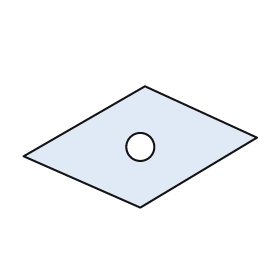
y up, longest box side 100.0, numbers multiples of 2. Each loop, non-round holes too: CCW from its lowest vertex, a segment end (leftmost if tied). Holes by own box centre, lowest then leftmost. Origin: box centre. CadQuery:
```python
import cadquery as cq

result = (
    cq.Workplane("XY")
    .moveTo(0.0, -26.0)
    .lineTo(50.0, 4.0)
    .lineTo(2.0, 26.0)
    .lineTo(-50.0, -4.0)
    .close()
    .moveTo(0.0, 0.0)
    .circle(6.0)
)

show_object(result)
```